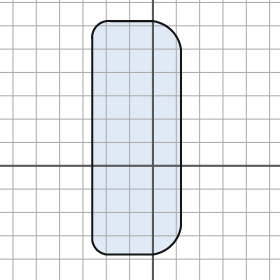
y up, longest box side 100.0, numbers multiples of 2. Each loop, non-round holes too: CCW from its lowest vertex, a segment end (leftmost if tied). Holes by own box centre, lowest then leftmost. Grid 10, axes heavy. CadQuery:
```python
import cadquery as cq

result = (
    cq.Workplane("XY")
    .moveTo(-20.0, -38.0)
    .lineTo(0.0, -38.0)
    .threePointArc((8.0, -34.0), (12.0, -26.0))
    .lineTo(12.0, 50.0)
    .threePointArc((8.0, 58.0), (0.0, 62.0))
    .lineTo(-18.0, 62.0)
    .threePointArc((-24.0, 60.0), (-26.0, 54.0))
    .lineTo(-26.0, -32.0)
    .threePointArc((-24.0, -36.0), (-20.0, -38.0))
    .close()
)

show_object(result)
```